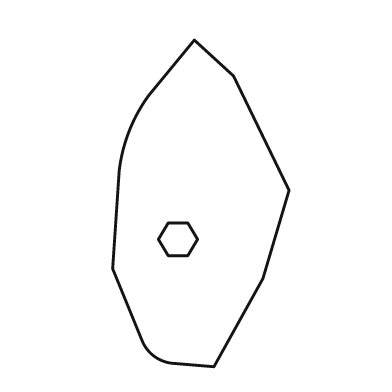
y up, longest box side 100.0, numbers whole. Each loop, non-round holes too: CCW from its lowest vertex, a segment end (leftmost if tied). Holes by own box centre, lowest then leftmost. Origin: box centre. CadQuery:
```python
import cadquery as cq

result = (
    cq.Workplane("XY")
    .moveTo(4.0, -50.0)
    .lineTo(19.0, -23.0)
    .lineTo(27.0, 4.0)
    .lineTo(10.0, 39.0)
    .lineTo(-2.0, 50.0)
    .lineTo(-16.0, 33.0)
    .threePointArc((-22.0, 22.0), (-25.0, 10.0))
    .lineTo(-27.0, -20.0)
    .lineTo(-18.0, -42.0)
    .threePointArc((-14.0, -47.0), (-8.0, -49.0))
    .close()
    .moveTo(-10.0, -16.0)
    .lineTo(-4.0, -16.0)
    .lineTo(-1.0, -11.0)
    .lineTo(-4.0, -6.0)
    .lineTo(-10.0, -6.0)
    .lineTo(-13.0, -11.0)
    .close()
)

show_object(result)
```